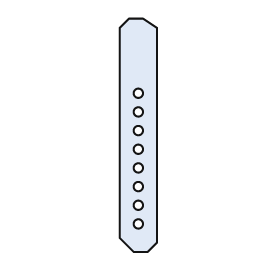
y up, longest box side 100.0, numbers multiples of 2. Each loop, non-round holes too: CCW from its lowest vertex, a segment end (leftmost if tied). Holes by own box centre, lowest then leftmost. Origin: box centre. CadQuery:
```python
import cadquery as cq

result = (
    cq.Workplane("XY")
    .moveTo(-2.0, -50.0)
    .lineTo(4.0, -50.0)
    .lineTo(8.0, -46.0)
    .lineTo(8.0, 46.0)
    .lineTo(2.0, 50.0)
    .lineTo(-4.0, 50.0)
    .lineTo(-8.0, 46.0)
    .lineTo(-8.0, -44.0)
    .close()
    .moveTo(0.0, -38.0)
    .circle(2.0)
    .moveTo(0.0, -30.0)
    .circle(2.0)
    .moveTo(0.0, -22.0)
    .circle(2.0)
    .moveTo(0.0, -14.0)
    .circle(2.0)
    .moveTo(0.0, -6.0)
    .circle(2.0)
    .moveTo(0.0, 2.0)
    .circle(2.0)
    .moveTo(0.0, 10.0)
    .circle(2.0)
    .moveTo(0.0, 18.0)
    .circle(2.0)
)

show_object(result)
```